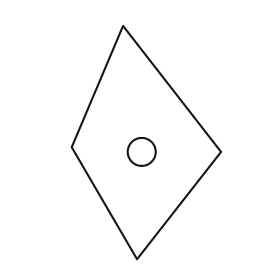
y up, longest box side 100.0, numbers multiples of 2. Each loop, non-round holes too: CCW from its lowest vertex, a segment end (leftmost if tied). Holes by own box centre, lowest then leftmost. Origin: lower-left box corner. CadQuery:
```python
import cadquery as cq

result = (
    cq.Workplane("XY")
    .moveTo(28.0, 0.0)
    .lineTo(64.0, 46.0)
    .lineTo(22.0, 100.0)
    .lineTo(0.0, 48.0)
    .close()
    .moveTo(30.0, 46.0)
    .circle(6.0)
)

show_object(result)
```